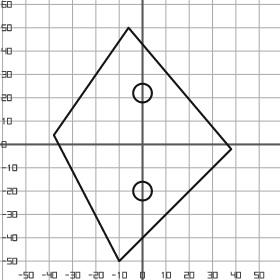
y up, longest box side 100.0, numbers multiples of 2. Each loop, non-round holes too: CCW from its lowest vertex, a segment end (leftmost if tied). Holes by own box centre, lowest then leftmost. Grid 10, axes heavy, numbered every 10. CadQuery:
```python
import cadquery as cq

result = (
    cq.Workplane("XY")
    .moveTo(-10.0, -50.0)
    .lineTo(38.0, -2.0)
    .lineTo(-6.0, 50.0)
    .lineTo(-38.0, 4.0)
    .close()
    .moveTo(0.0, -20.0)
    .circle(4.0)
    .moveTo(0.0, 22.0)
    .circle(4.0)
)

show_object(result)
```